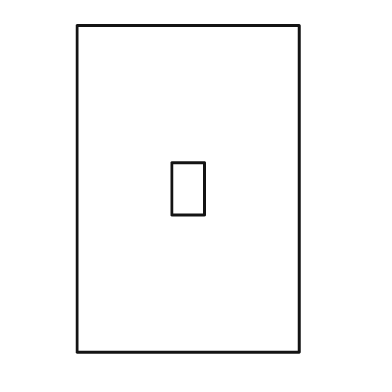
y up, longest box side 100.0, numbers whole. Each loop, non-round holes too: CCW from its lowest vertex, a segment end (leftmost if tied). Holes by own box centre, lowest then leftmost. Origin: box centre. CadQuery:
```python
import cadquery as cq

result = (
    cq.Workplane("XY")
    .moveTo(-34.0, -50.0)
    .lineTo(34.0, -50.0)
    .lineTo(34.0, 50.0)
    .lineTo(-34.0, 50.0)
    .close()
    .moveTo(-5.0, -8.0)
    .lineTo(5.0, -8.0)
    .lineTo(5.0, 8.0)
    .lineTo(-5.0, 8.0)
    .close()
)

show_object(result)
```